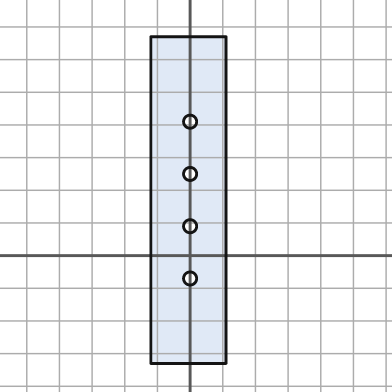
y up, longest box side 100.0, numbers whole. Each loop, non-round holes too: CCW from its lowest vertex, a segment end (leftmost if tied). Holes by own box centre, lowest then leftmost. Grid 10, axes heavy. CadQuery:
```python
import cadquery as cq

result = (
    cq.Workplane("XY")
    .moveTo(-12.0, -33.0)
    .lineTo(11.0, -33.0)
    .lineTo(11.0, 67.0)
    .lineTo(-12.0, 67.0)
    .close()
    .moveTo(0.0, -7.0)
    .circle(2.0)
    .moveTo(0.0, 9.0)
    .circle(2.0)
    .moveTo(0.0, 25.0)
    .circle(2.0)
    .moveTo(0.0, 41.0)
    .circle(2.0)
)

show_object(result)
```